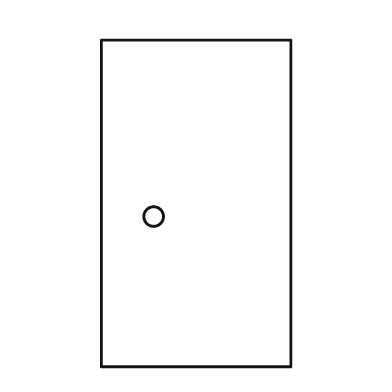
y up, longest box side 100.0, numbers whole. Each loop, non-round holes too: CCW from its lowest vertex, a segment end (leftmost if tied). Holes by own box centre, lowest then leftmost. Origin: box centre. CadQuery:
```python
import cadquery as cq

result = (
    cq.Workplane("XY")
    .moveTo(-29.0, -50.0)
    .lineTo(29.0, -50.0)
    .lineTo(29.0, 50.0)
    .lineTo(-29.0, 50.0)
    .close()
    .moveTo(-13.0, -4.0)
    .circle(3.0)
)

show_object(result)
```